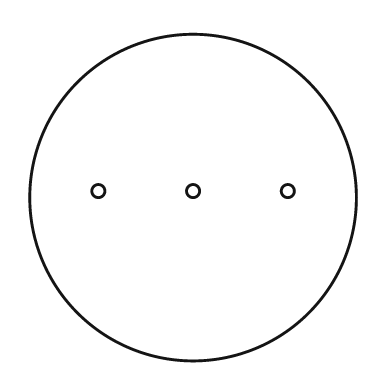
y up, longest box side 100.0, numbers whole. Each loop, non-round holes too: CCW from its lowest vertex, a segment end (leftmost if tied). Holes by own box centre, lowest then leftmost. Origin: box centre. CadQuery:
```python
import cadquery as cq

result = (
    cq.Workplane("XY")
    .moveTo(0.0, 0.0)
    .circle(50.0)
    .moveTo(-29.0, 2.0)
    .circle(2.0)
    .moveTo(0.0, 2.0)
    .circle(2.0)
    .moveTo(29.0, 2.0)
    .circle(2.0)
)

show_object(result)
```